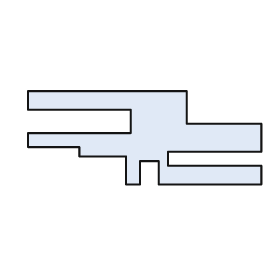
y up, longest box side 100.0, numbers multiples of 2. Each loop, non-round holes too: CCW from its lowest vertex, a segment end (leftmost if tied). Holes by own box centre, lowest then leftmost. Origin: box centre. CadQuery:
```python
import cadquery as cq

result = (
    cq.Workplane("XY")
    .moveTo(-8.0, -20.0)
    .lineTo(-2.0, -20.0)
    .lineTo(-2.0, -10.0)
    .lineTo(6.0, -10.0)
    .lineTo(6.0, -20.0)
    .lineTo(50.0, -20.0)
    .lineTo(50.0, -12.0)
    .lineTo(10.0, -12.0)
    .lineTo(10.0, -6.0)
    .lineTo(50.0, -6.0)
    .lineTo(50.0, 6.0)
    .lineTo(18.0, 6.0)
    .lineTo(18.0, 20.0)
    .lineTo(-50.0, 20.0)
    .lineTo(-50.0, 12.0)
    .lineTo(-6.0, 12.0)
    .lineTo(-6.0, 2.0)
    .lineTo(-50.0, 2.0)
    .lineTo(-50.0, -4.0)
    .lineTo(-28.0, -4.0)
    .lineTo(-28.0, -8.0)
    .lineTo(-8.0, -8.0)
    .close()
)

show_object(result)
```